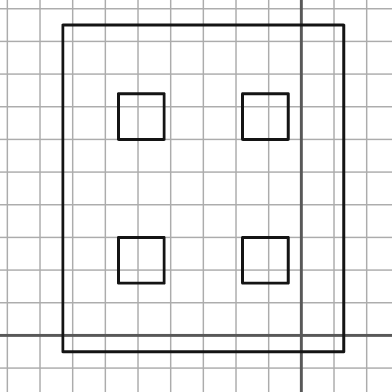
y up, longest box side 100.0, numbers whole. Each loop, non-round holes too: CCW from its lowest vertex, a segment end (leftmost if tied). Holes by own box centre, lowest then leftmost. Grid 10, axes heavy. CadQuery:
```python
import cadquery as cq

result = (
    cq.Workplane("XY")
    .moveTo(-73.0, -5.0)
    .lineTo(13.0, -5.0)
    .lineTo(13.0, 95.0)
    .lineTo(-73.0, 95.0)
    .close()
    .moveTo(-56.0, 16.0)
    .lineTo(-42.0, 16.0)
    .lineTo(-42.0, 30.0)
    .lineTo(-56.0, 30.0)
    .close()
    .moveTo(-18.0, 16.0)
    .lineTo(-4.0, 16.0)
    .lineTo(-4.0, 30.0)
    .lineTo(-18.0, 30.0)
    .close()
    .moveTo(-56.0, 60.0)
    .lineTo(-42.0, 60.0)
    .lineTo(-42.0, 74.0)
    .lineTo(-56.0, 74.0)
    .close()
    .moveTo(-18.0, 60.0)
    .lineTo(-4.0, 60.0)
    .lineTo(-4.0, 74.0)
    .lineTo(-18.0, 74.0)
    .close()
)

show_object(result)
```